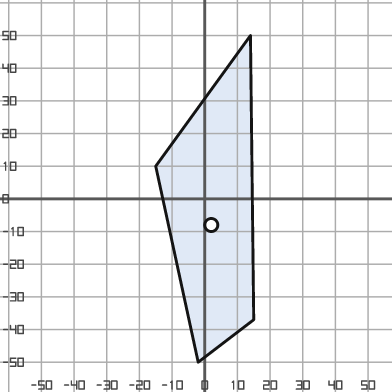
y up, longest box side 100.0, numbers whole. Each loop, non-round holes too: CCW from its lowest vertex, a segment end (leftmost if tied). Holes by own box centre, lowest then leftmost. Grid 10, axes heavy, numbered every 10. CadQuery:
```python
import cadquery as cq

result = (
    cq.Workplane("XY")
    .moveTo(-2.0, -50.0)
    .lineTo(15.0, -37.0)
    .lineTo(14.0, 50.0)
    .lineTo(-15.0, 10.0)
    .close()
    .moveTo(2.0, -8.0)
    .circle(2.0)
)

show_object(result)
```